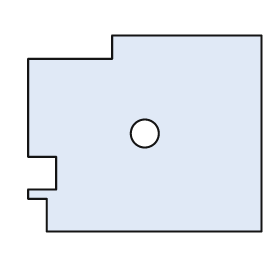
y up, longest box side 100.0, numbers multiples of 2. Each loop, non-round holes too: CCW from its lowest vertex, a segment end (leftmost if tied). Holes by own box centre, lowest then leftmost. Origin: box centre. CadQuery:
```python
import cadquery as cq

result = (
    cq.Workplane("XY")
    .moveTo(-42.0, -42.0)
    .lineTo(50.0, -42.0)
    .lineTo(50.0, 42.0)
    .lineTo(-14.0, 42.0)
    .lineTo(-14.0, 32.0)
    .lineTo(-50.0, 32.0)
    .lineTo(-50.0, -10.0)
    .lineTo(-38.0, -10.0)
    .lineTo(-38.0, -24.0)
    .lineTo(-50.0, -24.0)
    .lineTo(-50.0, -28.0)
    .lineTo(-42.0, -28.0)
    .close()
    .moveTo(0.0, 0.0)
    .circle(6.0)
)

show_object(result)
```